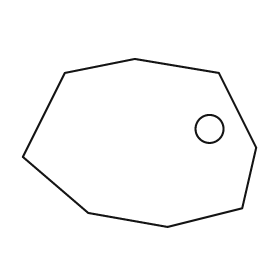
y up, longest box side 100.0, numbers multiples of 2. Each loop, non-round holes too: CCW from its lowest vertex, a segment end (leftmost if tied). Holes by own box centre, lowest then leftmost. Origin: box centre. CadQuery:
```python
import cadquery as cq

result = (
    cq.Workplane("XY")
    .moveTo(12.0, -36.0)
    .lineTo(44.0, -28.0)
    .lineTo(50.0, -2.0)
    .lineTo(34.0, 30.0)
    .lineTo(-2.0, 36.0)
    .lineTo(-32.0, 30.0)
    .lineTo(-50.0, -6.0)
    .lineTo(-22.0, -30.0)
    .close()
    .moveTo(30.0, 6.0)
    .circle(6.0)
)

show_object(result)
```